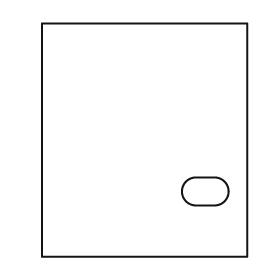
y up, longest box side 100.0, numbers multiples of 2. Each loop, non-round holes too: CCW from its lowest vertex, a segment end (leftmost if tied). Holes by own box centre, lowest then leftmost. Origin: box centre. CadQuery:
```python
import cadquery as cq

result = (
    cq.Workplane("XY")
    .moveTo(-44.0, -50.0)
    .lineTo(44.0, -50.0)
    .lineTo(44.0, 50.0)
    .lineTo(-44.0, 50.0)
    .close()
    .moveTo(22.0, -28.0)
    .lineTo(30.0, -28.0)
    .threePointArc((36.0, -22.0), (30.0, -16.0))
    .lineTo(22.0, -16.0)
    .threePointArc((16.0, -22.0), (22.0, -28.0))
    .close()
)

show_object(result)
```